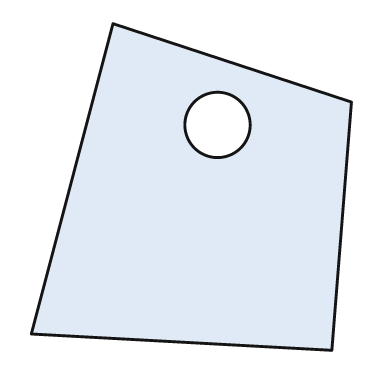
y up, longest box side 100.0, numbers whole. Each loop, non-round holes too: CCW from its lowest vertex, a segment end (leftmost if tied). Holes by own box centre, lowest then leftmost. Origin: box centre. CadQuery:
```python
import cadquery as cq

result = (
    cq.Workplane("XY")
    .moveTo(43.0, -50.0)
    .lineTo(49.0, 26.0)
    .lineTo(-24.0, 50.0)
    .lineTo(-49.0, -45.0)
    .close()
    .moveTo(8.0, 19.0)
    .circle(10.0)
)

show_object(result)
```